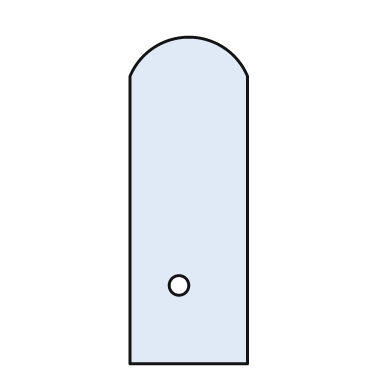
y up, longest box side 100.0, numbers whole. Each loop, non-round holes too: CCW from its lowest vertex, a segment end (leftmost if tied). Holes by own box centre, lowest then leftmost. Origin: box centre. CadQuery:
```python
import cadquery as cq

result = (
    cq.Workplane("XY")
    .moveTo(-18.0, -50.0)
    .lineTo(18.0, -50.0)
    .lineTo(18.0, 38.0)
    .threePointArc((0.0, 50.0), (-18.0, 38.0))
    .close()
    .moveTo(-3.0, -26.0)
    .circle(3.0)
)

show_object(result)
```